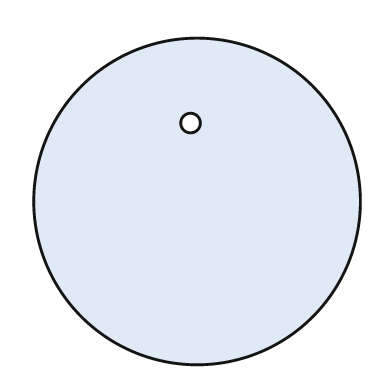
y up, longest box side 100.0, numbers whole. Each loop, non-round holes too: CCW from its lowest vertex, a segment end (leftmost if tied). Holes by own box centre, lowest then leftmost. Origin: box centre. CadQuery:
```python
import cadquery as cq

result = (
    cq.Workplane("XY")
    .moveTo(0.0, 0.0)
    .circle(50.0)
    .moveTo(-2.0, 24.0)
    .circle(3.0)
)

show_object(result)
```